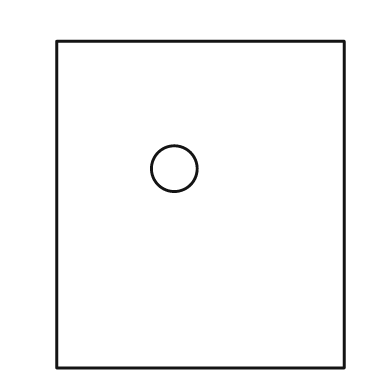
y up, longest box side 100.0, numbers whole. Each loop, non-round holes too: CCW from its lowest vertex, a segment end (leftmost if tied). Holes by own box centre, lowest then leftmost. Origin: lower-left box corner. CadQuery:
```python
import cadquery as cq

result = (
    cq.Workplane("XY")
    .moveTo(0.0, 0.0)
    .lineTo(88.0, 0.0)
    .lineTo(88.0, 100.0)
    .lineTo(0.0, 100.0)
    .close()
    .moveTo(36.0, 61.0)
    .circle(7.0)
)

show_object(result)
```